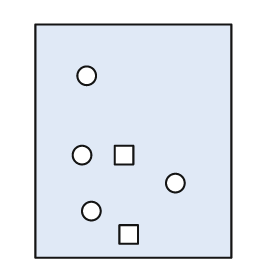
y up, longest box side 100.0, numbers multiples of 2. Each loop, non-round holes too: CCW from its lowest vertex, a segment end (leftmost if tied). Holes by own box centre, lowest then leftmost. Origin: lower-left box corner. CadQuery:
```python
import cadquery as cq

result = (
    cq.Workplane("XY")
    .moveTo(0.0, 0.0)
    .lineTo(84.0, 0.0)
    .lineTo(84.0, 100.0)
    .lineTo(0.0, 100.0)
    .close()
    .moveTo(36.0, 6.0)
    .lineTo(44.0, 6.0)
    .lineTo(44.0, 14.0)
    .lineTo(36.0, 14.0)
    .close()
    .moveTo(24.0, 20.0)
    .circle(4.0)
    .moveTo(60.0, 32.0)
    .circle(4.0)
    .moveTo(20.0, 44.0)
    .circle(4.0)
    .moveTo(34.0, 40.0)
    .lineTo(42.0, 40.0)
    .lineTo(42.0, 48.0)
    .lineTo(34.0, 48.0)
    .close()
    .moveTo(22.0, 78.0)
    .circle(4.0)
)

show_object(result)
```